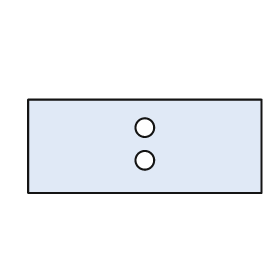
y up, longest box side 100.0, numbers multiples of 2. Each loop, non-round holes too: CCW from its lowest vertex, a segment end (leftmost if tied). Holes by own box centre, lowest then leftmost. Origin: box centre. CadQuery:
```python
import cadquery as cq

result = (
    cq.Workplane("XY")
    .moveTo(-50.0, -20.0)
    .lineTo(50.0, -20.0)
    .lineTo(50.0, 20.0)
    .lineTo(-50.0, 20.0)
    .close()
    .moveTo(0.0, -6.0)
    .circle(4.0)
    .moveTo(0.0, 8.0)
    .circle(4.0)
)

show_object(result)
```